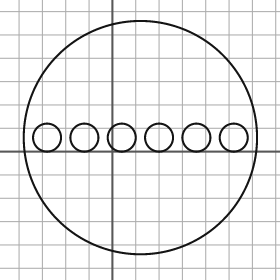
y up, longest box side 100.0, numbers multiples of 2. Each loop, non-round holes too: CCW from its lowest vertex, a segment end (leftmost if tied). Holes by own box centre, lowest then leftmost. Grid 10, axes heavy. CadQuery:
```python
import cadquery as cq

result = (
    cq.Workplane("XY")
    .moveTo(12.0, 6.0)
    .circle(50.0)
    .moveTo(-28.0, 6.0)
    .circle(6.0)
    .moveTo(-12.0, 6.0)
    .circle(6.0)
    .moveTo(4.0, 6.0)
    .circle(6.0)
    .moveTo(20.0, 6.0)
    .circle(6.0)
    .moveTo(36.0, 6.0)
    .circle(6.0)
    .moveTo(52.0, 6.0)
    .circle(6.0)
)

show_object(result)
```